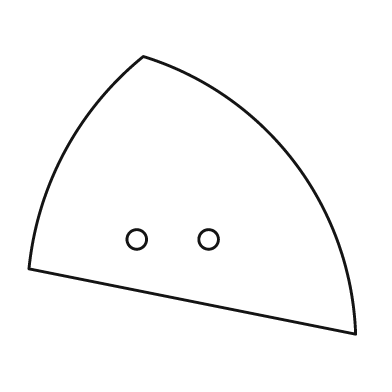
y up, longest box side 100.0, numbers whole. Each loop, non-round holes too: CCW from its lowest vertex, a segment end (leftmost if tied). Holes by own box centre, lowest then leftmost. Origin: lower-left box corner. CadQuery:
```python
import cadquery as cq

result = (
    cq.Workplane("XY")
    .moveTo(100.0, 0.0)
    .threePointArc((81.0, 53.0), (35.0, 85.0))
    .threePointArc((11.0, 56.0), (0.0, 20.0))
    .close()
    .moveTo(33.0, 29.0)
    .circle(3.0)
    .moveTo(55.0, 29.0)
    .circle(3.0)
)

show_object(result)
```